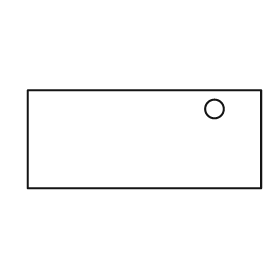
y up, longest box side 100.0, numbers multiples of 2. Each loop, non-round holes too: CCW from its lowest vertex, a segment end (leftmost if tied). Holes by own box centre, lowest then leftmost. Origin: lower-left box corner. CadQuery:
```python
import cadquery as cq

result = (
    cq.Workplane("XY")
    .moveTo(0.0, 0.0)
    .lineTo(100.0, 0.0)
    .lineTo(100.0, 42.0)
    .lineTo(0.0, 42.0)
    .close()
    .moveTo(80.0, 34.0)
    .circle(4.0)
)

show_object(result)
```